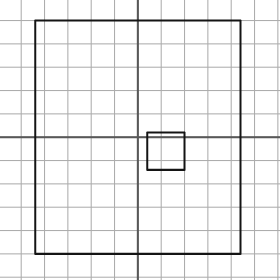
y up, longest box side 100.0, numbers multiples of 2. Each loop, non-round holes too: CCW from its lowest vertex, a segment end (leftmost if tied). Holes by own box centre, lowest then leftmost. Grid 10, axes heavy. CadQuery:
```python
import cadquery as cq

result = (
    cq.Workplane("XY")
    .moveTo(-44.0, -50.0)
    .lineTo(44.0, -50.0)
    .lineTo(44.0, 50.0)
    .lineTo(-44.0, 50.0)
    .close()
    .moveTo(4.0, -14.0)
    .lineTo(20.0, -14.0)
    .lineTo(20.0, 2.0)
    .lineTo(4.0, 2.0)
    .close()
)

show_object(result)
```